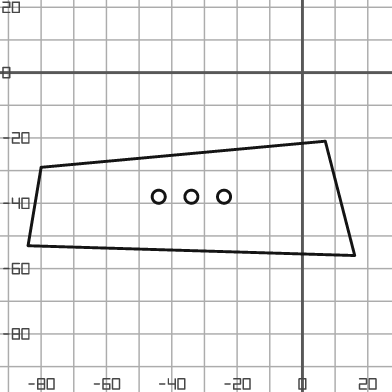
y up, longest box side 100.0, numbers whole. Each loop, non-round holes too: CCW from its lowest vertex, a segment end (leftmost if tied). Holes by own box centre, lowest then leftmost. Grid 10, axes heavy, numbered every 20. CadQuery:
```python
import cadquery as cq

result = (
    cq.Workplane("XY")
    .moveTo(16.0, -56.0)
    .lineTo(7.0, -21.0)
    .lineTo(-80.0, -29.0)
    .lineTo(-84.0, -53.0)
    .close()
    .moveTo(-44.0, -38.0)
    .circle(2.0)
    .moveTo(-34.0, -38.0)
    .circle(2.0)
    .moveTo(-24.0, -38.0)
    .circle(2.0)
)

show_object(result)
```